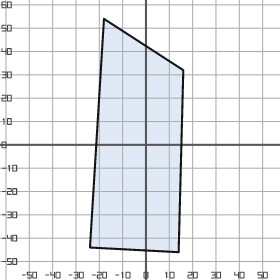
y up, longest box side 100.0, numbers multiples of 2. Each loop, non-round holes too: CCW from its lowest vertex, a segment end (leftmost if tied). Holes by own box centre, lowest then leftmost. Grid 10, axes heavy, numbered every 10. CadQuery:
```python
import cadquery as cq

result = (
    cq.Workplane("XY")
    .moveTo(14.0, -46.0)
    .lineTo(16.0, 32.0)
    .lineTo(-18.0, 54.0)
    .lineTo(-24.0, -44.0)
    .close()
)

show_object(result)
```